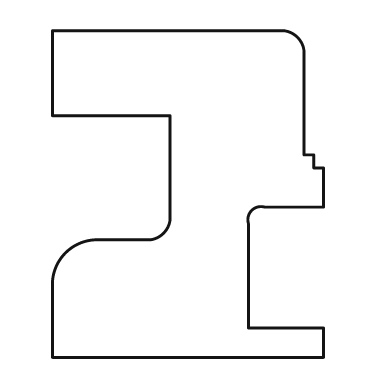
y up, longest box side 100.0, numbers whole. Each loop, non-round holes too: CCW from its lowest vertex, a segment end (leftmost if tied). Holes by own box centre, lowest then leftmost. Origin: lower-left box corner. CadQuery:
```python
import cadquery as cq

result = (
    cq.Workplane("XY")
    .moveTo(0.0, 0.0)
    .lineTo(83.0, 0.0)
    .lineTo(83.0, 9.0)
    .lineTo(60.0, 9.0)
    .lineTo(60.0, 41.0)
    .threePointArc((61.0, 45.0), (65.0, 46.0))
    .lineTo(83.0, 46.0)
    .lineTo(83.0, 58.0)
    .lineTo(80.0, 58.0)
    .lineTo(80.0, 62.0)
    .lineTo(77.0, 62.0)
    .lineTo(77.0, 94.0)
    .threePointArc((75.0, 98.0), (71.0, 100.0))
    .lineTo(0.0, 100.0)
    .lineTo(0.0, 74.0)
    .lineTo(36.0, 74.0)
    .lineTo(36.0, 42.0)
    .threePointArc((34.0, 38.0), (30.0, 36.0))
    .lineTo(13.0, 36.0)
    .threePointArc((4.0, 32.0), (0.0, 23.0))
    .close()
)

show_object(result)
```